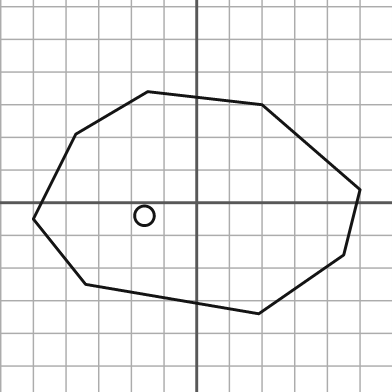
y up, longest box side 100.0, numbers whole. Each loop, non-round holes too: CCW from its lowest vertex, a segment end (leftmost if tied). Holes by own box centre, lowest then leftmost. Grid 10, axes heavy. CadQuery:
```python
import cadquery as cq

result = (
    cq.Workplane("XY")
    .moveTo(19.0, -34.0)
    .lineTo(45.0, -16.0)
    .lineTo(50.0, 4.0)
    .lineTo(20.0, 30.0)
    .lineTo(-15.0, 34.0)
    .lineTo(-37.0, 21.0)
    .lineTo(-50.0, -5.0)
    .lineTo(-34.0, -25.0)
    .close()
    .moveTo(-16.0, -4.0)
    .circle(3.0)
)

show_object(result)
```